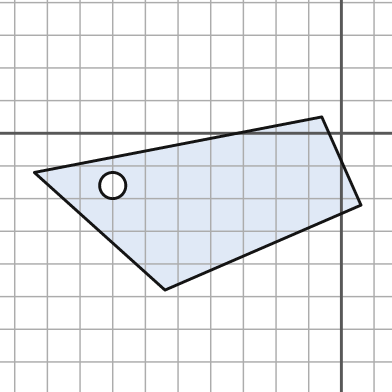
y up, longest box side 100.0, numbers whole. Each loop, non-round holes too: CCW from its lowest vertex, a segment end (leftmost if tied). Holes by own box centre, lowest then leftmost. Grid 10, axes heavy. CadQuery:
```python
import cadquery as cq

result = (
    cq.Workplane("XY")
    .moveTo(-54.0, -48.0)
    .lineTo(6.0, -22.0)
    .lineTo(-6.0, 5.0)
    .lineTo(-94.0, -12.0)
    .close()
    .moveTo(-70.0, -16.0)
    .circle(4.0)
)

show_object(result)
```